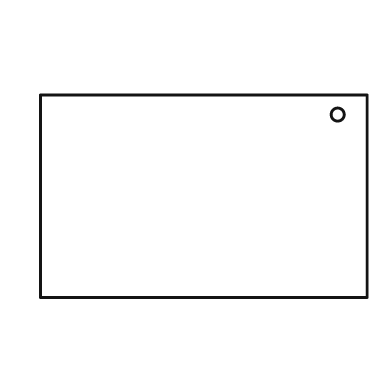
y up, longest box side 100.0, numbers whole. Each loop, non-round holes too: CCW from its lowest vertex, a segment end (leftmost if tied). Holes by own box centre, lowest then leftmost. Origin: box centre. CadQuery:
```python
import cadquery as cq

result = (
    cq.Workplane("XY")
    .moveTo(-50.0, -31.0)
    .lineTo(50.0, -31.0)
    .lineTo(50.0, 31.0)
    .lineTo(-50.0, 31.0)
    .close()
    .moveTo(41.0, 25.0)
    .circle(2.0)
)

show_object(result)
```